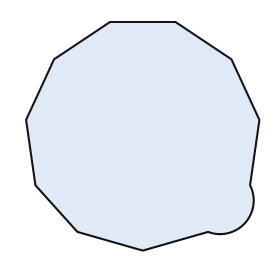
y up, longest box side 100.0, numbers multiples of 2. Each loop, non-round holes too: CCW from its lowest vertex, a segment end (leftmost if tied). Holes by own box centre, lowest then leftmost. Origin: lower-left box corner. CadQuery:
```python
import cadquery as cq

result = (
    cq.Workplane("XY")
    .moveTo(50.0, 0.0)
    .lineTo(78.0, 8.0)
    .threePointArc((94.0, 12.0), (96.0, 28.0))
    .lineTo(100.0, 56.0)
    .lineTo(88.0, 82.0)
    .lineTo(64.0, 98.0)
    .lineTo(36.0, 98.0)
    .lineTo(12.0, 82.0)
    .lineTo(0.0, 56.0)
    .lineTo(4.0, 28.0)
    .lineTo(22.0, 8.0)
    .close()
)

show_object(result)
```